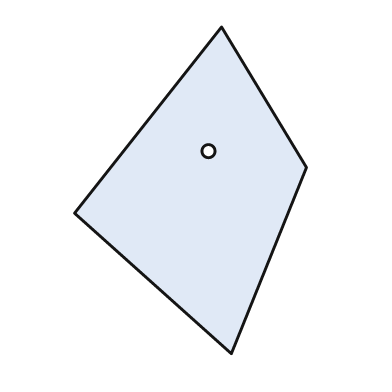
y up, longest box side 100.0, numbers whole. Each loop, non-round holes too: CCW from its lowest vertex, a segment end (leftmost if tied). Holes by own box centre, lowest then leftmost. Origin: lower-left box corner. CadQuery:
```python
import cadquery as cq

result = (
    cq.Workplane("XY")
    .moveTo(48.0, 0.0)
    .lineTo(71.0, 57.0)
    .lineTo(45.0, 100.0)
    .lineTo(0.0, 43.0)
    .close()
    .moveTo(41.0, 62.0)
    .circle(2.0)
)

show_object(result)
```